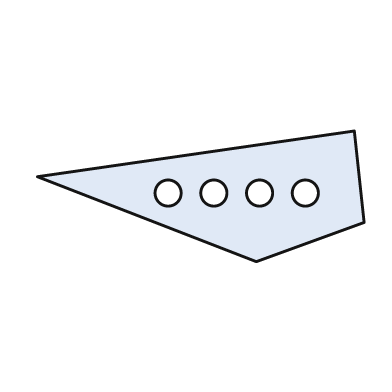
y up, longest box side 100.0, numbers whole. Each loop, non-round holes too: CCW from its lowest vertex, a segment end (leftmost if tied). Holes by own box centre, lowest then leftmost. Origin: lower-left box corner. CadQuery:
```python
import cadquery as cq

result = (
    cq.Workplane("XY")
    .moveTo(67.0, 0.0)
    .lineTo(100.0, 12.0)
    .lineTo(97.0, 40.0)
    .lineTo(0.0, 26.0)
    .close()
    .moveTo(40.0, 21.0)
    .circle(4.0)
    .moveTo(54.0, 21.0)
    .circle(4.0)
    .moveTo(68.0, 21.0)
    .circle(4.0)
    .moveTo(82.0, 21.0)
    .circle(4.0)
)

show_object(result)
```